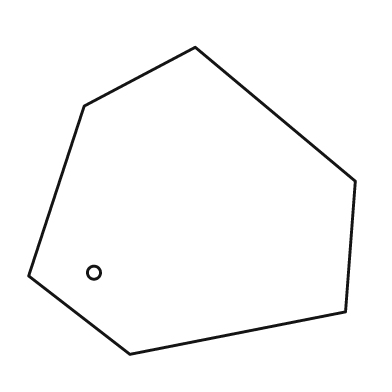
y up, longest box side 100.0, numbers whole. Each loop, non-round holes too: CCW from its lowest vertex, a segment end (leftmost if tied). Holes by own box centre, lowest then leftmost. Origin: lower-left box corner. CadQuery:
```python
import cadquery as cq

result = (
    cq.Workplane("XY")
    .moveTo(31.0, 0.0)
    .lineTo(97.0, 13.0)
    .lineTo(100.0, 53.0)
    .lineTo(51.0, 94.0)
    .lineTo(17.0, 76.0)
    .lineTo(0.0, 24.0)
    .close()
    .moveTo(20.0, 25.0)
    .circle(2.0)
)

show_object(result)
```